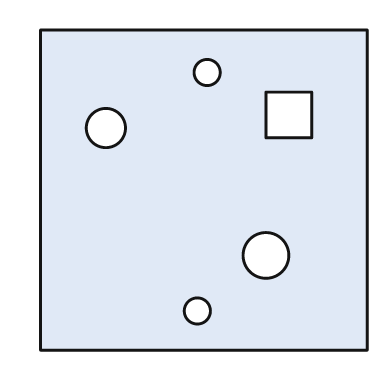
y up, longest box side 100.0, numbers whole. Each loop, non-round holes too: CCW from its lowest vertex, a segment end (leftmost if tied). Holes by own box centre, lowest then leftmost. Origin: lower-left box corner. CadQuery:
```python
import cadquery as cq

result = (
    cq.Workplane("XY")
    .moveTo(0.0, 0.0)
    .lineTo(100.0, 0.0)
    .lineTo(100.0, 98.0)
    .lineTo(0.0, 98.0)
    .close()
    .moveTo(48.0, 12.0)
    .circle(4.0)
    .moveTo(69.0, 29.0)
    .circle(7.0)
    .moveTo(20.0, 68.0)
    .circle(6.0)
    .moveTo(69.0, 65.0)
    .lineTo(83.0, 65.0)
    .lineTo(83.0, 79.0)
    .lineTo(69.0, 79.0)
    .close()
    .moveTo(51.0, 85.0)
    .circle(4.0)
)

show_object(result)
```